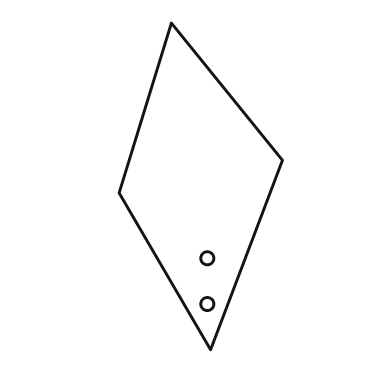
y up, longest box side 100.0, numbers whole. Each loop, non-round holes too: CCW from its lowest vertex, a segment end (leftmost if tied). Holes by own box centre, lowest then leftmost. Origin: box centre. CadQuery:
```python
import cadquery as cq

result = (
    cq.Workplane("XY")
    .moveTo(3.0, -50.0)
    .lineTo(25.0, 8.0)
    .lineTo(-9.0, 50.0)
    .lineTo(-25.0, -2.0)
    .close()
    .moveTo(2.0, -36.0)
    .circle(2.0)
    .moveTo(2.0, -22.0)
    .circle(2.0)
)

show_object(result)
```